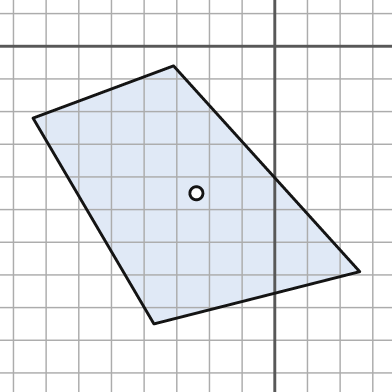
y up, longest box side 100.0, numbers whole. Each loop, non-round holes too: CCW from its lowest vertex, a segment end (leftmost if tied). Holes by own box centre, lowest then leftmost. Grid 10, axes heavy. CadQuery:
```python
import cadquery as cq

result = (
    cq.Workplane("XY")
    .moveTo(-37.0, -85.0)
    .lineTo(26.0, -69.0)
    .lineTo(-31.0, -6.0)
    .lineTo(-74.0, -22.0)
    .close()
    .moveTo(-24.0, -45.0)
    .circle(2.0)
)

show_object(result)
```